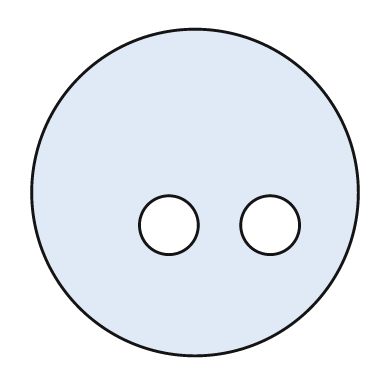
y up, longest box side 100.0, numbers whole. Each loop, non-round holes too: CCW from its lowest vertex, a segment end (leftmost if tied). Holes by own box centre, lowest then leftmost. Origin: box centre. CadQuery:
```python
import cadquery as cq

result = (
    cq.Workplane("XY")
    .moveTo(0.0, 0.0)
    .circle(50.0)
    .moveTo(-8.0, -10.0)
    .circle(9.0)
    .moveTo(23.0, -10.0)
    .circle(9.0)
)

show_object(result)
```